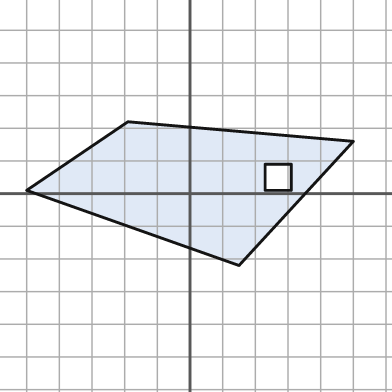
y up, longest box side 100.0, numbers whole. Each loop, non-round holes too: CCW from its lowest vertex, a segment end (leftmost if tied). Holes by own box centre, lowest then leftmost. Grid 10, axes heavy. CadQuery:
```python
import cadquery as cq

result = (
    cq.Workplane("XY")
    .moveTo(15.0, -22.0)
    .lineTo(50.0, 16.0)
    .lineTo(-19.0, 22.0)
    .lineTo(-50.0, 1.0)
    .close()
    .moveTo(23.0, 1.0)
    .lineTo(31.0, 1.0)
    .lineTo(31.0, 9.0)
    .lineTo(23.0, 9.0)
    .close()
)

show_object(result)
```